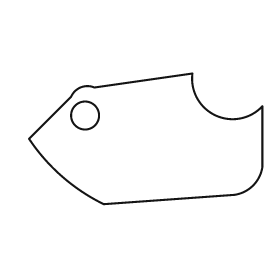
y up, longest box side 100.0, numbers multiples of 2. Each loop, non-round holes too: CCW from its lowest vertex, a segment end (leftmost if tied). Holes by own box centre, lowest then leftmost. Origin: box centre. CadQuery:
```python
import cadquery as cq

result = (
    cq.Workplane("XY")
    .moveTo(-18.0, -28.0)
    .lineTo(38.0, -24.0)
    .threePointArc((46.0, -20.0), (50.0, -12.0))
    .lineTo(50.0, 14.0)
    .threePointArc((30.0, 10.0), (20.0, 28.0))
    .lineTo(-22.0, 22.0)
    .threePointArc((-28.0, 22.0), (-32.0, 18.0))
    .lineTo(-50.0, 0.0)
    .threePointArc((-36.0, -16.0), (-18.0, -28.0))
    .close()
    .moveTo(-26.0, 10.0)
    .circle(6.0)
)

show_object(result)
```